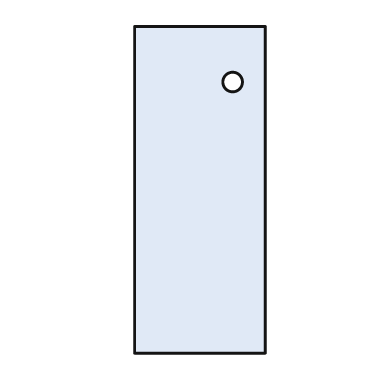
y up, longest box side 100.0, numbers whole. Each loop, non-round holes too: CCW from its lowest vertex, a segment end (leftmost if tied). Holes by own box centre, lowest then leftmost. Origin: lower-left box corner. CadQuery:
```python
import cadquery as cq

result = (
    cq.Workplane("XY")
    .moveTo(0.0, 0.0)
    .lineTo(40.0, 0.0)
    .lineTo(40.0, 100.0)
    .lineTo(0.0, 100.0)
    .close()
    .moveTo(30.0, 83.0)
    .circle(3.0)
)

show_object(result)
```